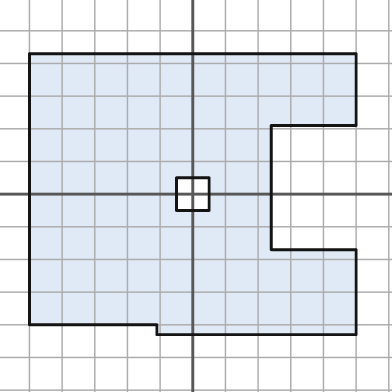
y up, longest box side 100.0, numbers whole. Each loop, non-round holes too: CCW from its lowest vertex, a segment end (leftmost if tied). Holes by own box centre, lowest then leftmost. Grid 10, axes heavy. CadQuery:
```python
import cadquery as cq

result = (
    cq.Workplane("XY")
    .moveTo(-11.0, -43.0)
    .lineTo(50.0, -43.0)
    .lineTo(50.0, -17.0)
    .lineTo(24.0, -17.0)
    .lineTo(24.0, 21.0)
    .lineTo(50.0, 21.0)
    .lineTo(50.0, 43.0)
    .lineTo(-50.0, 43.0)
    .lineTo(-50.0, -40.0)
    .lineTo(-11.0, -40.0)
    .close()
    .moveTo(-5.0, -5.0)
    .lineTo(5.0, -5.0)
    .lineTo(5.0, 5.0)
    .lineTo(-5.0, 5.0)
    .close()
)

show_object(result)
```